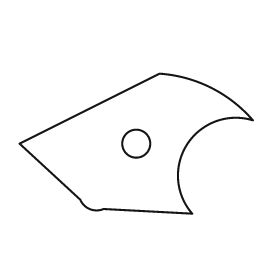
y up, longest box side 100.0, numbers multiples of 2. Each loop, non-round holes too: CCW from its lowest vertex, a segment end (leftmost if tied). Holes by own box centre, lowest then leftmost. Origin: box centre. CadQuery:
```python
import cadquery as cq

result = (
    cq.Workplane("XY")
    .moveTo(24.0, -30.0)
    .threePointArc((22.0, 0.0), (50.0, 10.0))
    .threePointArc((32.0, 24.0), (10.0, 30.0))
    .lineTo(-50.0, 0.0)
    .lineTo(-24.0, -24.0)
    .threePointArc((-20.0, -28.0), (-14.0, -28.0))
    .close()
    .moveTo(0.0, 0.0)
    .circle(6.0)
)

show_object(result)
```